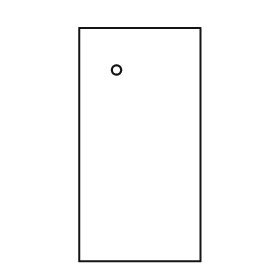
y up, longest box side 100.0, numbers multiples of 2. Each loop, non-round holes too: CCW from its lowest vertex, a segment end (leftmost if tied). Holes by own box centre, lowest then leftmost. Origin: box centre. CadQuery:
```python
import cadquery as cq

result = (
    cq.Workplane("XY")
    .moveTo(-26.0, -50.0)
    .lineTo(26.0, -50.0)
    .lineTo(26.0, 50.0)
    .lineTo(-26.0, 50.0)
    .close()
    .moveTo(-10.0, 32.0)
    .circle(2.0)
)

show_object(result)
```